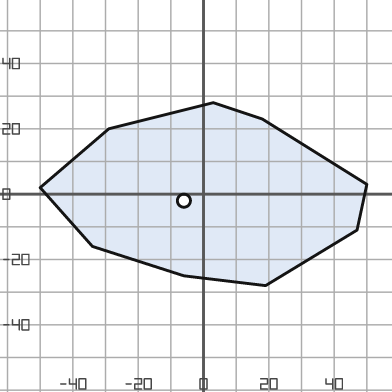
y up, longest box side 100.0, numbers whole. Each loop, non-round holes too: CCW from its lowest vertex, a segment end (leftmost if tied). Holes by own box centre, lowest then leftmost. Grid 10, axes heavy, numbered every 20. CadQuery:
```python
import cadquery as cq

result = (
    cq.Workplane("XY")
    .moveTo(19.0, -28.0)
    .lineTo(47.0, -11.0)
    .lineTo(50.0, 3.0)
    .lineTo(18.0, 23.0)
    .lineTo(3.0, 28.0)
    .lineTo(-29.0, 20.0)
    .lineTo(-50.0, 2.0)
    .lineTo(-34.0, -16.0)
    .lineTo(-6.0, -25.0)
    .close()
    .moveTo(-6.0, -2.0)
    .circle(2.0)
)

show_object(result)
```